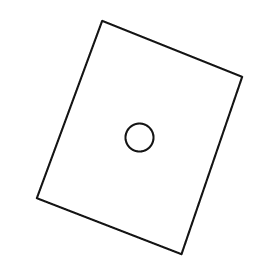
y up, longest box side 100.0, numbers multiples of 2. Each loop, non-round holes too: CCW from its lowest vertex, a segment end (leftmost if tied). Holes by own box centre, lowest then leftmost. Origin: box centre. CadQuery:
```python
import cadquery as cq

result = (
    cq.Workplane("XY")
    .moveTo(18.0, -50.0)
    .lineTo(44.0, 26.0)
    .lineTo(-16.0, 50.0)
    .lineTo(-44.0, -26.0)
    .close()
    .moveTo(0.0, 0.0)
    .circle(6.0)
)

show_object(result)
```